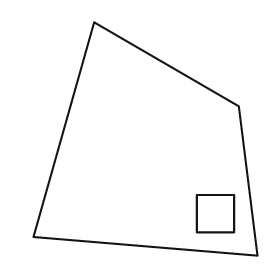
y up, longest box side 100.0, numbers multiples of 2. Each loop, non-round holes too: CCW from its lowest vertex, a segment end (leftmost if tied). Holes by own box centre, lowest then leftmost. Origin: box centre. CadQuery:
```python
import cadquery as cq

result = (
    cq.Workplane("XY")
    .moveTo(48.0, -50.0)
    .lineTo(40.0, 14.0)
    .lineTo(-22.0, 50.0)
    .lineTo(-48.0, -42.0)
    .close()
    .moveTo(22.0, -40.0)
    .lineTo(38.0, -40.0)
    .lineTo(38.0, -24.0)
    .lineTo(22.0, -24.0)
    .close()
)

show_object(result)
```